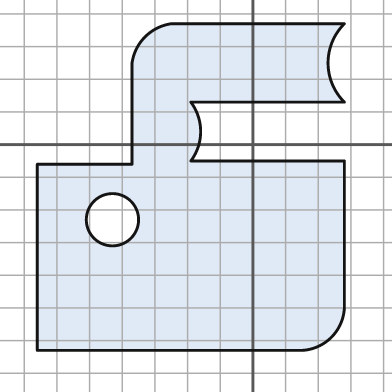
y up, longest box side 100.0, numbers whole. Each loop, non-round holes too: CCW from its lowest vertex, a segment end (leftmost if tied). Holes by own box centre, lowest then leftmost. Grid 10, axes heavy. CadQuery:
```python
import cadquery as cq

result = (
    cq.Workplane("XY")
    .moveTo(-66.0, -63.0)
    .lineTo(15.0, -63.0)
    .threePointArc((24.0, -59.0), (28.0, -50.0))
    .lineTo(28.0, -5.0)
    .lineTo(-19.0, -5.0)
    .threePointArc((-16.0, 4.0), (-19.0, 13.0))
    .lineTo(28.0, 13.0)
    .threePointArc((23.0, 25.0), (28.0, 37.0))
    .lineTo(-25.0, 37.0)
    .threePointArc((-33.0, 33.0), (-37.0, 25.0))
    .lineTo(-37.0, -6.0)
    .lineTo(-66.0, -6.0)
    .close()
    .moveTo(-43.0, -23.0)
    .circle(8.0)
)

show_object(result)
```